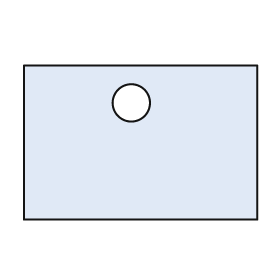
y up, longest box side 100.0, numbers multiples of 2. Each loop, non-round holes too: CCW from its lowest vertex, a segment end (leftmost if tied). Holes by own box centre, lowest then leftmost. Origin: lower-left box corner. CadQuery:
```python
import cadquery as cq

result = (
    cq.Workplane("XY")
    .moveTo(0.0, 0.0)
    .lineTo(100.0, 0.0)
    .lineTo(100.0, 66.0)
    .lineTo(0.0, 66.0)
    .close()
    .moveTo(46.0, 50.0)
    .circle(8.0)
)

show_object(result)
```